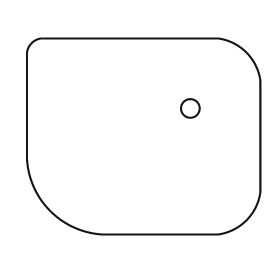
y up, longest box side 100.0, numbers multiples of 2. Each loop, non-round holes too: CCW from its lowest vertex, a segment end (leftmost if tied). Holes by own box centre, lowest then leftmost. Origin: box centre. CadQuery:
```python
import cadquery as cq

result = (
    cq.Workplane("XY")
    .moveTo(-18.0, -42.0)
    .lineTo(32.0, -42.0)
    .threePointArc((44.0, -36.0), (50.0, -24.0))
    .lineTo(50.0, 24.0)
    .threePointArc((44.0, 36.0), (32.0, 42.0))
    .lineTo(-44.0, 42.0)
    .threePointArc((-48.0, 40.0), (-50.0, 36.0))
    .lineTo(-50.0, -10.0)
    .threePointArc((-40.0, -32.0), (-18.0, -42.0))
    .close()
    .moveTo(20.0, 12.0)
    .circle(4.0)
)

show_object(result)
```